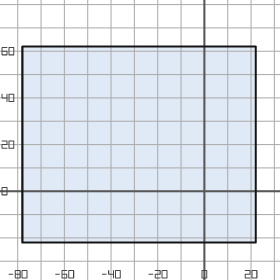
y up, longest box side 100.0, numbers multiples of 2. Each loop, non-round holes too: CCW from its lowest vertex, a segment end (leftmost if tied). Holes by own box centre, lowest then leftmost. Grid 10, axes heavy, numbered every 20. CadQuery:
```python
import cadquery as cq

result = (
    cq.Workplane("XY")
    .moveTo(-78.0, -22.0)
    .lineTo(22.0, -22.0)
    .lineTo(22.0, 62.0)
    .lineTo(-78.0, 62.0)
    .close()
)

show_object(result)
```